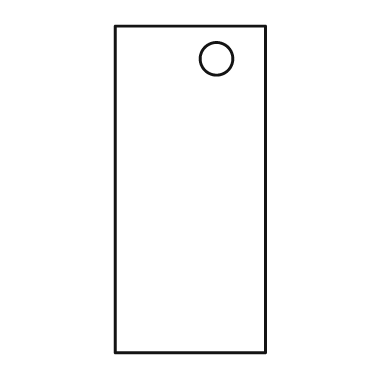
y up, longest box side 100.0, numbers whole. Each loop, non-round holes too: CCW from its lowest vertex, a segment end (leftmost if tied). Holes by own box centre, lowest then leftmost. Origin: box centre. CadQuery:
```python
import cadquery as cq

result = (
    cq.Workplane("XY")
    .moveTo(-23.0, -50.0)
    .lineTo(23.0, -50.0)
    .lineTo(23.0, 50.0)
    .lineTo(-23.0, 50.0)
    .close()
    .moveTo(8.0, 40.0)
    .circle(5.0)
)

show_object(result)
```